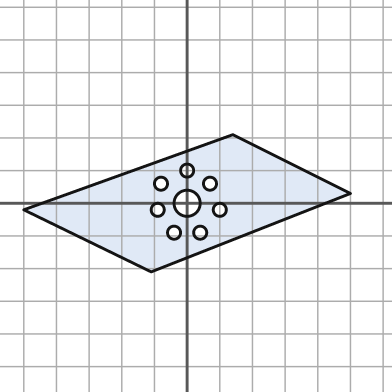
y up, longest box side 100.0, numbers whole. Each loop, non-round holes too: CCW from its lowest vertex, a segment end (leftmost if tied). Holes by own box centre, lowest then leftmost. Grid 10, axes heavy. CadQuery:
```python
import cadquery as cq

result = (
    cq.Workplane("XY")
    .moveTo(-11.0, -21.0)
    .lineTo(50.0, 3.0)
    .lineTo(14.0, 21.0)
    .lineTo(-50.0, -2.0)
    .close()
    .moveTo(-4.0, -9.0)
    .circle(2.0)
    .moveTo(4.0, -9.0)
    .circle(2.0)
    .moveTo(-9.0, -2.0)
    .circle(2.0)
    .moveTo(10.0, -2.0)
    .circle(2.0)
    .moveTo(0.0, 0.0)
    .circle(4.0)
    .moveTo(-8.0, 6.0)
    .circle(2.0)
    .moveTo(7.0, 6.0)
    .circle(2.0)
    .moveTo(0.0, 10.0)
    .circle(2.0)
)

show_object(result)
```